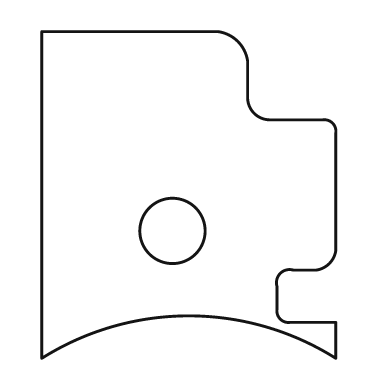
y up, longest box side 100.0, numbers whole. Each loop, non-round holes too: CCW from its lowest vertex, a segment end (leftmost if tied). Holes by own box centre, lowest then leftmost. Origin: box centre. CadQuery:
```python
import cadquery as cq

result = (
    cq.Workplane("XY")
    .moveTo(-45.0, -50.0)
    .threePointArc((0.0, -37.0), (45.0, -50.0))
    .lineTo(45.0, -39.0)
    .lineTo(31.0, -39.0)
    .threePointArc((28.0, -38.0), (27.0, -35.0))
    .lineTo(27.0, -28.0)
    .threePointArc((28.0, -24.0), (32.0, -23.0))
    .lineTo(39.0, -23.0)
    .threePointArc((43.0, -21.0), (45.0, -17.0))
    .lineTo(45.0, 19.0)
    .threePointArc((44.0, 22.0), (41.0, 23.0))
    .lineTo(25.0, 23.0)
    .threePointArc((20.0, 25.0), (18.0, 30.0))
    .lineTo(18.0, 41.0)
    .threePointArc((15.0, 47.0), (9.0, 50.0))
    .lineTo(-45.0, 50.0)
    .close()
    .moveTo(-5.0, -11.0)
    .circle(10.0)
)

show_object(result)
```